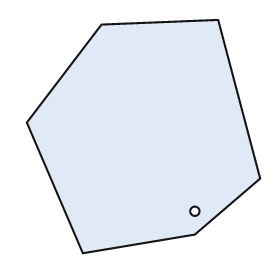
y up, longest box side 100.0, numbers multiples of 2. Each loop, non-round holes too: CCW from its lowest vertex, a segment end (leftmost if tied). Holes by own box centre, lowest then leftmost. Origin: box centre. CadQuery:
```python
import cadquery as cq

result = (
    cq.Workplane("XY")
    .moveTo(-26.0, -50.0)
    .lineTo(22.0, -42.0)
    .lineTo(50.0, -18.0)
    .lineTo(32.0, 50.0)
    .lineTo(-18.0, 48.0)
    .lineTo(-50.0, 6.0)
    .close()
    .moveTo(22.0, -32.0)
    .circle(2.0)
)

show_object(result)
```